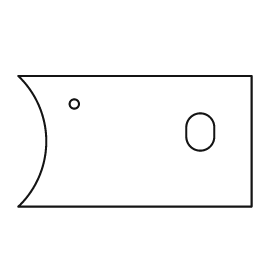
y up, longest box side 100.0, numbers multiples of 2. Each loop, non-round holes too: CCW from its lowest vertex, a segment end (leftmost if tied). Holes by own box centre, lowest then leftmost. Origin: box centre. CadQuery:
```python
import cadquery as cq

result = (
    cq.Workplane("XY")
    .moveTo(-50.0, -28.0)
    .lineTo(50.0, -28.0)
    .lineTo(50.0, 28.0)
    .lineTo(-50.0, 28.0)
    .threePointArc((-38.0, 0.0), (-50.0, -28.0))
    .close()
    .moveTo(22.0, 2.0)
    .threePointArc((28.0, -4.0), (34.0, 2.0))
    .lineTo(34.0, 6.0)
    .threePointArc((28.0, 12.0), (22.0, 6.0))
    .close()
    .moveTo(-26.0, 16.0)
    .circle(2.0)
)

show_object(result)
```